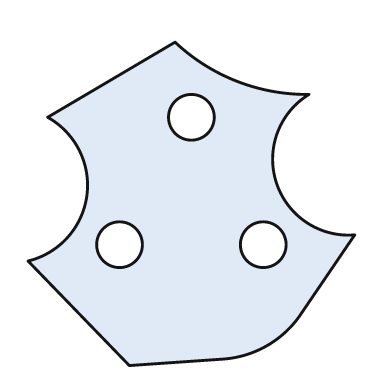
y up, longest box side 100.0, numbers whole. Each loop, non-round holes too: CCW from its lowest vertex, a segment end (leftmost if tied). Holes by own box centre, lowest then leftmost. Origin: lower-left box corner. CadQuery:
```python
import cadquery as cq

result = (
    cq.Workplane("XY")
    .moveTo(31.0, 0.0)
    .lineTo(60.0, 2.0)
    .threePointArc((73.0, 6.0), (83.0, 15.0))
    .lineTo(100.0, 40.0)
    .threePointArc((76.0, 56.0), (86.0, 83.0))
    .threePointArc((64.0, 87.0), (45.0, 99.0))
    .lineTo(6.0, 76.0)
    .threePointArc((18.0, 52.0), (0.0, 32.0))
    .close()
    .moveTo(28.0, 37.0)
    .circle(7.0)
    .moveTo(72.0, 37.0)
    .circle(7.0)
    .moveTo(50.0, 76.0)
    .circle(7.0)
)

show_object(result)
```